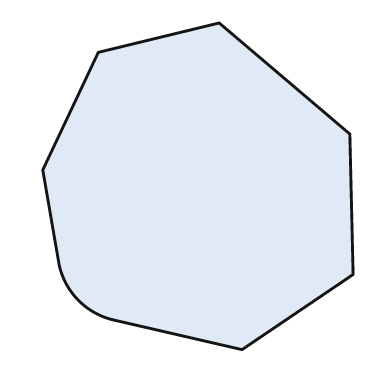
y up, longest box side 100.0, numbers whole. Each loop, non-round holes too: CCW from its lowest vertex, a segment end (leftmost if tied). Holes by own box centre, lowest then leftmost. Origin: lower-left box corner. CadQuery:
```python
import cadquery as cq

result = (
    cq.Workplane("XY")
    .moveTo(61.0, 0.0)
    .lineTo(95.0, 23.0)
    .lineTo(94.0, 66.0)
    .lineTo(54.0, 100.0)
    .lineTo(17.0, 91.0)
    .lineTo(0.0, 55.0)
    .lineTo(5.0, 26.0)
    .threePointArc((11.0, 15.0), (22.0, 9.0))
    .close()
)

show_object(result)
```